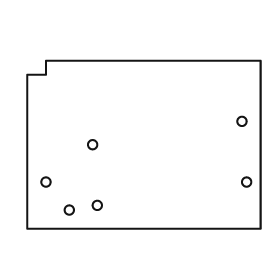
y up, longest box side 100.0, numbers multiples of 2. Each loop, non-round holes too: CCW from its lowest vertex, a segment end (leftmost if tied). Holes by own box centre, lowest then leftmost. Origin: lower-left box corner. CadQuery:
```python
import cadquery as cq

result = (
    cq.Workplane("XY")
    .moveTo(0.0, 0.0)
    .lineTo(100.0, 0.0)
    .lineTo(100.0, 72.0)
    .lineTo(8.0, 72.0)
    .lineTo(8.0, 66.0)
    .lineTo(0.0, 66.0)
    .close()
    .moveTo(18.0, 8.0)
    .circle(2.0)
    .moveTo(30.0, 10.0)
    .circle(2.0)
    .moveTo(8.0, 20.0)
    .circle(2.0)
    .moveTo(94.0, 20.0)
    .circle(2.0)
    .moveTo(28.0, 36.0)
    .circle(2.0)
    .moveTo(92.0, 46.0)
    .circle(2.0)
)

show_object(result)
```